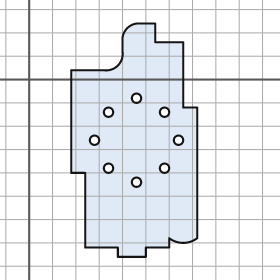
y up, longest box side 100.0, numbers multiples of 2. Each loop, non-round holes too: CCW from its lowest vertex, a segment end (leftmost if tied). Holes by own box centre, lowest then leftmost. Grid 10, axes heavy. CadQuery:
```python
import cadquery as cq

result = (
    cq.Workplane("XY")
    .moveTo(38.0, -76.0)
    .lineTo(50.0, -76.0)
    .lineTo(50.0, -72.0)
    .lineTo(60.0, -72.0)
    .lineTo(60.0, -68.0)
    .threePointArc((66.0, -70.0), (72.0, -68.0))
    .lineTo(72.0, -12.0)
    .lineTo(66.0, -12.0)
    .lineTo(66.0, 16.0)
    .lineTo(54.0, 16.0)
    .lineTo(54.0, 24.0)
    .lineTo(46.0, 24.0)
    .threePointArc((42.0, 22.0), (40.0, 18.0))
    .lineTo(40.0, 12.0)
    .threePointArc((38.0, 6.0), (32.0, 4.0))
    .lineTo(18.0, 4.0)
    .lineTo(18.0, -40.0)
    .lineTo(24.0, -40.0)
    .lineTo(24.0, -72.0)
    .lineTo(38.0, -72.0)
    .close()
    .moveTo(46.0, -44.0)
    .circle(2.0)
    .moveTo(34.0, -38.0)
    .circle(2.0)
    .moveTo(58.0, -38.0)
    .circle(2.0)
    .moveTo(28.0, -26.0)
    .circle(2.0)
    .moveTo(64.0, -26.0)
    .circle(2.0)
    .moveTo(34.0, -14.0)
    .circle(2.0)
    .moveTo(58.0, -14.0)
    .circle(2.0)
    .moveTo(46.0, -8.0)
    .circle(2.0)
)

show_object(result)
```